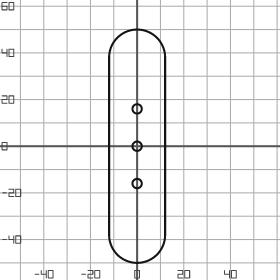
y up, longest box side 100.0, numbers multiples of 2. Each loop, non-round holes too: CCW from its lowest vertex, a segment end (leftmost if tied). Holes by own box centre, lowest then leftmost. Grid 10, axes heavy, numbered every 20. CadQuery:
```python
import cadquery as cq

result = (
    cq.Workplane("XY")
    .moveTo(-12.0, -38.0)
    .threePointArc((0.0, -50.0), (12.0, -38.0))
    .lineTo(12.0, 38.0)
    .threePointArc((0.0, 50.0), (-12.0, 38.0))
    .close()
    .moveTo(0.0, -16.0)
    .circle(2.0)
    .moveTo(0.0, 0.0)
    .circle(2.0)
    .moveTo(0.0, 16.0)
    .circle(2.0)
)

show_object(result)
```